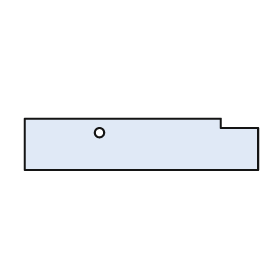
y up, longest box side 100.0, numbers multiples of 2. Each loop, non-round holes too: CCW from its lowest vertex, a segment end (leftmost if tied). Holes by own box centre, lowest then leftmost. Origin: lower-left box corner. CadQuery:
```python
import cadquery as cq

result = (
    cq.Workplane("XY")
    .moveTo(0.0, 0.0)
    .lineTo(100.0, 0.0)
    .lineTo(100.0, 18.0)
    .lineTo(84.0, 18.0)
    .lineTo(84.0, 22.0)
    .lineTo(0.0, 22.0)
    .close()
    .moveTo(32.0, 16.0)
    .circle(2.0)
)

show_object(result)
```